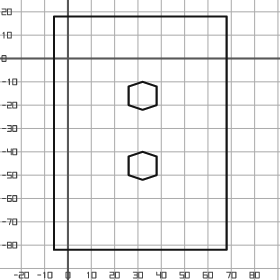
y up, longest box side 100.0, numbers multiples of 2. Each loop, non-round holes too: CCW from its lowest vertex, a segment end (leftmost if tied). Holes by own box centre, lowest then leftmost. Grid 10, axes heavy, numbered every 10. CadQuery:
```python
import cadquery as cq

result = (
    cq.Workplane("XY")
    .moveTo(-6.0, -82.0)
    .lineTo(68.0, -82.0)
    .lineTo(68.0, 18.0)
    .lineTo(-6.0, 18.0)
    .close()
    .moveTo(32.0, -52.0)
    .lineTo(38.0, -50.0)
    .lineTo(38.0, -42.0)
    .lineTo(32.0, -40.0)
    .lineTo(26.0, -42.0)
    .lineTo(26.0, -50.0)
    .close()
    .moveTo(32.0, -22.0)
    .lineTo(38.0, -20.0)
    .lineTo(38.0, -12.0)
    .lineTo(32.0, -10.0)
    .lineTo(26.0, -12.0)
    .lineTo(26.0, -20.0)
    .close()
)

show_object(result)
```